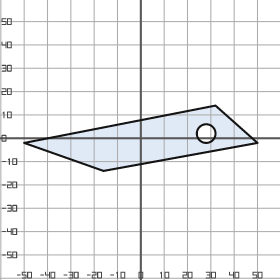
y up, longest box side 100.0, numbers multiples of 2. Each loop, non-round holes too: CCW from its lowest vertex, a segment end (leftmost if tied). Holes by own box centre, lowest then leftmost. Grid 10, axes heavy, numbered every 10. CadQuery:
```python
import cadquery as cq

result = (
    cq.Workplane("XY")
    .moveTo(-16.0, -14.0)
    .lineTo(50.0, -2.0)
    .lineTo(32.0, 14.0)
    .lineTo(-50.0, -2.0)
    .close()
    .moveTo(28.0, 2.0)
    .circle(4.0)
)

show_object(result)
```